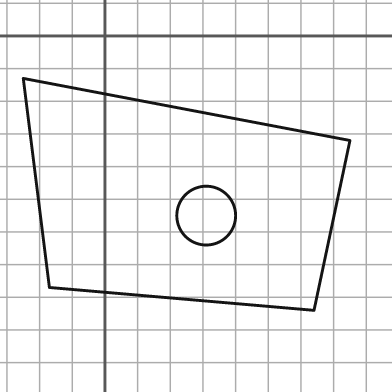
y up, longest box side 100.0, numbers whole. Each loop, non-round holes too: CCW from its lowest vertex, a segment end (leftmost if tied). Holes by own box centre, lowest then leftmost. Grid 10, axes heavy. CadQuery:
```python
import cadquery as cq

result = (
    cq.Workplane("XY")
    .moveTo(64.0, -84.0)
    .lineTo(75.0, -32.0)
    .lineTo(-25.0, -13.0)
    .lineTo(-17.0, -77.0)
    .close()
    .moveTo(31.0, -55.0)
    .circle(9.0)
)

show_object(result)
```